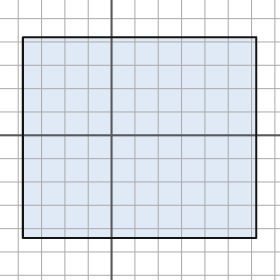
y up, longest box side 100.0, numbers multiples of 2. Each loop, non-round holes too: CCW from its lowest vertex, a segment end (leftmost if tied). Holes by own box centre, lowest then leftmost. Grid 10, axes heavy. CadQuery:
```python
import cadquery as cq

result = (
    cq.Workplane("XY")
    .moveTo(-38.0, -44.0)
    .lineTo(62.0, -44.0)
    .lineTo(62.0, 42.0)
    .lineTo(-38.0, 42.0)
    .close()
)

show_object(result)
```